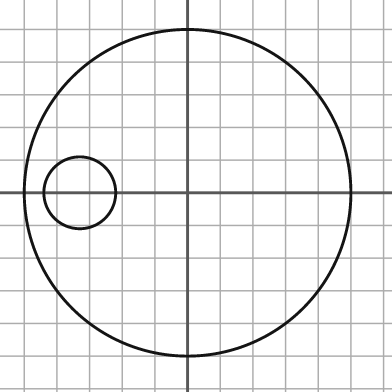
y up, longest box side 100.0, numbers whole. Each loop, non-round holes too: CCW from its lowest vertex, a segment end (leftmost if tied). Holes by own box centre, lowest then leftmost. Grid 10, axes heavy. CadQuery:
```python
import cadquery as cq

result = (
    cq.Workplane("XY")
    .moveTo(0.0, 0.0)
    .circle(50.0)
    .moveTo(-33.0, 0.0)
    .circle(11.0)
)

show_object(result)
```